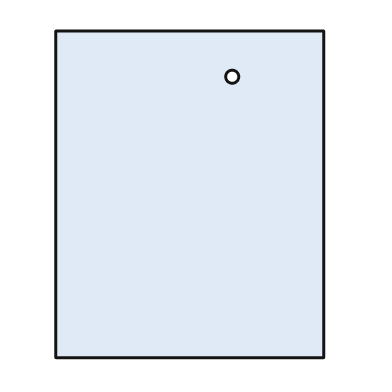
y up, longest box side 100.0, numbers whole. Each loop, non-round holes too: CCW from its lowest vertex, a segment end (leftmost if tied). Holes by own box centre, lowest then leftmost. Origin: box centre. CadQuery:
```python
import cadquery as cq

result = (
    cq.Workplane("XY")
    .moveTo(-41.0, -50.0)
    .lineTo(41.0, -50.0)
    .lineTo(41.0, 50.0)
    .lineTo(-41.0, 50.0)
    .close()
    .moveTo(13.0, 36.0)
    .circle(2.0)
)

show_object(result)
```